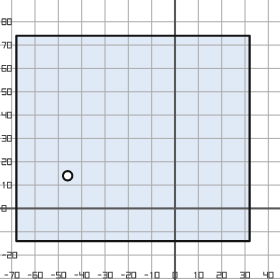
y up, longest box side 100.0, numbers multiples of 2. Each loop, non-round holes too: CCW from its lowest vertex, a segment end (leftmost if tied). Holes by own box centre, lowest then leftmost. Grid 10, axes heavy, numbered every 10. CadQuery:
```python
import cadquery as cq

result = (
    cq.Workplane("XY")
    .moveTo(-68.0, -14.0)
    .lineTo(32.0, -14.0)
    .lineTo(32.0, 74.0)
    .lineTo(-68.0, 74.0)
    .close()
    .moveTo(-46.0, 14.0)
    .circle(2.0)
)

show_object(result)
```